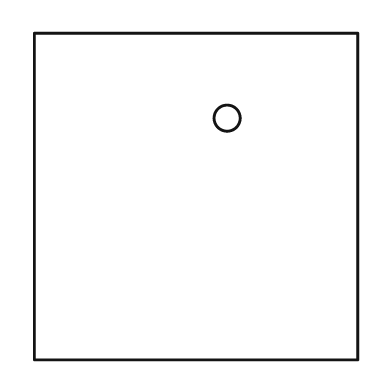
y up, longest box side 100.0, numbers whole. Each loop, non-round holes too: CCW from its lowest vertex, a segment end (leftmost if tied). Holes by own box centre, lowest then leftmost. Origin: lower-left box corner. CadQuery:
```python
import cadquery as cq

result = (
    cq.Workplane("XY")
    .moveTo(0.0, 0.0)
    .lineTo(99.0, 0.0)
    .lineTo(99.0, 100.0)
    .lineTo(0.0, 100.0)
    .close()
    .moveTo(59.0, 74.0)
    .circle(4.0)
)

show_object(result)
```